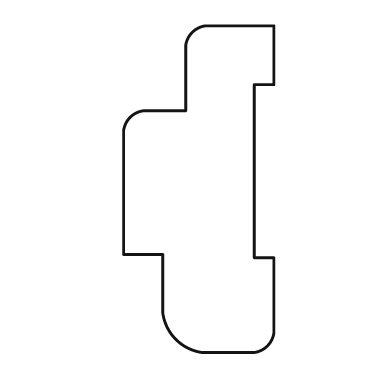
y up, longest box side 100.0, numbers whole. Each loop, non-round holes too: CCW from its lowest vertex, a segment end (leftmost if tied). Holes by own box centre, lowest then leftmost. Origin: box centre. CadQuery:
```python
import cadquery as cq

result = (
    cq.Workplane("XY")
    .moveTo(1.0, -50.0)
    .lineTo(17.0, -50.0)
    .threePointArc((21.0, -48.0), (23.0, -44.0))
    .lineTo(23.0, -21.0)
    .lineTo(17.0, -21.0)
    .lineTo(17.0, 32.0)
    .lineTo(23.0, 32.0)
    .lineTo(23.0, 50.0)
    .lineTo(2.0, 50.0)
    .threePointArc((-2.0, 48.0), (-4.0, 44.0))
    .lineTo(-4.0, 24.0)
    .lineTo(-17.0, 24.0)
    .threePointArc((-21.0, 22.0), (-23.0, 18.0))
    .lineTo(-23.0, -20.0)
    .lineTo(-11.0, -20.0)
    .lineTo(-11.0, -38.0)
    .threePointArc((-7.0, -46.0), (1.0, -50.0))
    .close()
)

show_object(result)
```